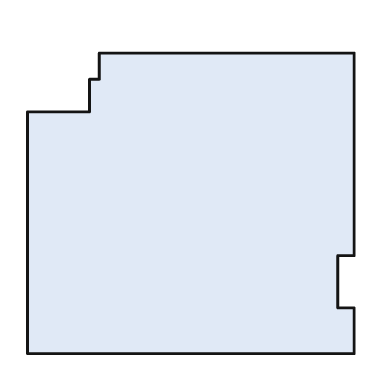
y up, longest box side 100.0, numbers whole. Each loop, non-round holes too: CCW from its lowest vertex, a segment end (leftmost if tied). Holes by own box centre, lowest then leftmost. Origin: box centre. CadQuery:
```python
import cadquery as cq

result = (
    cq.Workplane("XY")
    .moveTo(-50.0, -46.0)
    .lineTo(50.0, -46.0)
    .lineTo(50.0, -32.0)
    .lineTo(45.0, -32.0)
    .lineTo(45.0, -16.0)
    .lineTo(50.0, -16.0)
    .lineTo(50.0, 46.0)
    .lineTo(-28.0, 46.0)
    .lineTo(-28.0, 38.0)
    .lineTo(-31.0, 38.0)
    .lineTo(-31.0, 28.0)
    .lineTo(-50.0, 28.0)
    .close()
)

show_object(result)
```